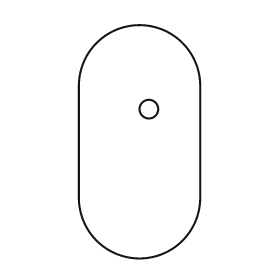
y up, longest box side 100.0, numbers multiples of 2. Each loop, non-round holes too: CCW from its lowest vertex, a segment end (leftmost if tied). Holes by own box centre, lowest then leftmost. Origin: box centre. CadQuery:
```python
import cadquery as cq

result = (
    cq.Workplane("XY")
    .moveTo(-26.0, -24.0)
    .threePointArc((0.0, -50.0), (26.0, -24.0))
    .lineTo(26.0, 24.0)
    .threePointArc((0.0, 50.0), (-26.0, 24.0))
    .close()
    .moveTo(4.0, 14.0)
    .circle(4.0)
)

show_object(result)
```